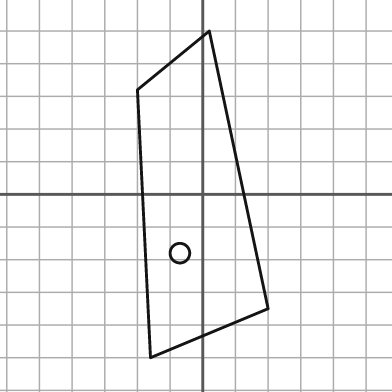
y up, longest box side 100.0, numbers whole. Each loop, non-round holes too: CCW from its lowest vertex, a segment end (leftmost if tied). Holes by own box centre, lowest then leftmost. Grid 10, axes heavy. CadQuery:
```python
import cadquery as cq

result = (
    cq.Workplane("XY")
    .moveTo(-16.0, -50.0)
    .lineTo(20.0, -35.0)
    .lineTo(2.0, 50.0)
    .lineTo(-20.0, 32.0)
    .close()
    .moveTo(-7.0, -18.0)
    .circle(3.0)
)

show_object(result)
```